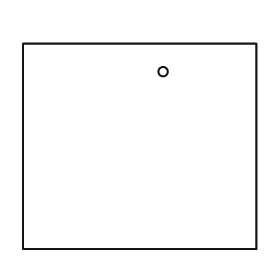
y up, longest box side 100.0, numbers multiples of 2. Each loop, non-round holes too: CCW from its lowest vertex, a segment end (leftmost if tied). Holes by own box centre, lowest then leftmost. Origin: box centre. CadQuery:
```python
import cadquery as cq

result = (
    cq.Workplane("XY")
    .moveTo(-50.0, -44.0)
    .lineTo(50.0, -44.0)
    .lineTo(50.0, 44.0)
    .lineTo(-50.0, 44.0)
    .close()
    .moveTo(10.0, 32.0)
    .circle(2.0)
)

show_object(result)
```